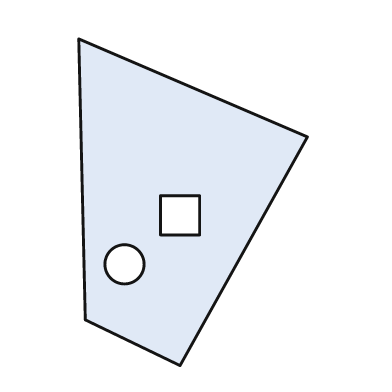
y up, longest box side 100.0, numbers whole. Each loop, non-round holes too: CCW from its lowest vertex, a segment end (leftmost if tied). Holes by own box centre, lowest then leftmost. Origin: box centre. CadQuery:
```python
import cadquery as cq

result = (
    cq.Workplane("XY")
    .moveTo(-4.0, -50.0)
    .lineTo(35.0, 20.0)
    .lineTo(-35.0, 50.0)
    .lineTo(-33.0, -36.0)
    .close()
    .moveTo(-21.0, -19.0)
    .circle(6.0)
    .moveTo(-10.0, -10.0)
    .lineTo(2.0, -10.0)
    .lineTo(2.0, 2.0)
    .lineTo(-10.0, 2.0)
    .close()
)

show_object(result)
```